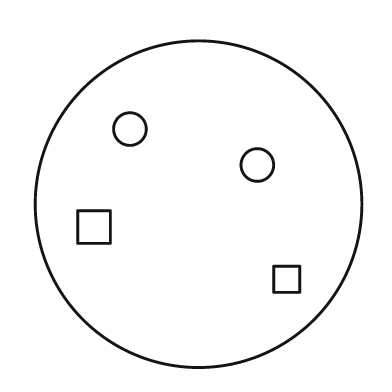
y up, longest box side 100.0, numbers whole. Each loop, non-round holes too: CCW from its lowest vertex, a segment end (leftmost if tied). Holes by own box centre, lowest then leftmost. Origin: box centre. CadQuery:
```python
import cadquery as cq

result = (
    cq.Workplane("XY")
    .moveTo(0.0, 0.0)
    .circle(50.0)
    .moveTo(23.0, -27.0)
    .lineTo(31.0, -27.0)
    .lineTo(31.0, -19.0)
    .lineTo(23.0, -19.0)
    .close()
    .moveTo(-37.0, -12.0)
    .lineTo(-27.0, -12.0)
    .lineTo(-27.0, -2.0)
    .lineTo(-37.0, -2.0)
    .close()
    .moveTo(18.0, 12.0)
    .circle(5.0)
    .moveTo(-21.0, 23.0)
    .circle(5.0)
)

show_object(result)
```